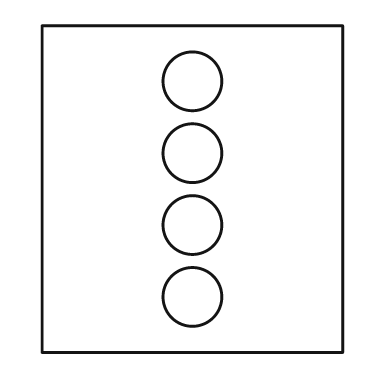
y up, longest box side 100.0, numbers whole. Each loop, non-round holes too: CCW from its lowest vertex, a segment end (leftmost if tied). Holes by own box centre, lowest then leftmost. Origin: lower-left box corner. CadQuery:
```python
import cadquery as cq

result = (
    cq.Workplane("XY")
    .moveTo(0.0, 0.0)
    .lineTo(92.0, 0.0)
    .lineTo(92.0, 100.0)
    .lineTo(0.0, 100.0)
    .close()
    .moveTo(46.0, 17.0)
    .circle(9.0)
    .moveTo(46.0, 39.0)
    .circle(9.0)
    .moveTo(46.0, 61.0)
    .circle(9.0)
    .moveTo(46.0, 83.0)
    .circle(9.0)
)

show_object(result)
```